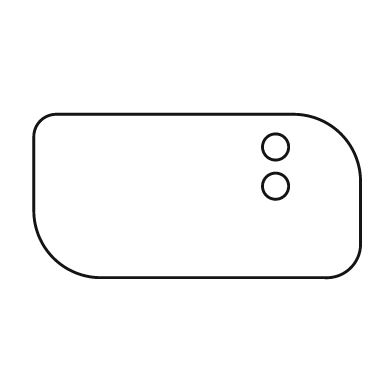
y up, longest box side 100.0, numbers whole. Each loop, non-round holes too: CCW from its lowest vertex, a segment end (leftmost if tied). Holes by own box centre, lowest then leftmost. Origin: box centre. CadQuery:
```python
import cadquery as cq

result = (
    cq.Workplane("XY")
    .moveTo(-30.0, -25.0)
    .lineTo(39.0, -25.0)
    .threePointArc((47.0, -22.0), (50.0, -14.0))
    .lineTo(50.0, 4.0)
    .threePointArc((44.0, 19.0), (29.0, 25.0))
    .lineTo(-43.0, 25.0)
    .threePointArc((-48.0, 23.0), (-50.0, 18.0))
    .lineTo(-50.0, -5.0)
    .threePointArc((-44.0, -19.0), (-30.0, -25.0))
    .close()
    .moveTo(24.0, 3.0)
    .circle(4.0)
    .moveTo(24.0, 15.0)
    .circle(4.0)
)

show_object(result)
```